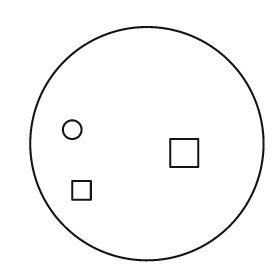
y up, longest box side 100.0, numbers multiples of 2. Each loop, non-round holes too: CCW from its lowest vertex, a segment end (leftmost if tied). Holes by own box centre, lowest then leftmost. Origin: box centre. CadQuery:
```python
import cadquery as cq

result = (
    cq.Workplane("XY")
    .moveTo(0.0, 0.0)
    .circle(50.0)
    .moveTo(-32.0, -24.0)
    .lineTo(-24.0, -24.0)
    .lineTo(-24.0, -16.0)
    .lineTo(-32.0, -16.0)
    .close()
    .moveTo(10.0, -10.0)
    .lineTo(22.0, -10.0)
    .lineTo(22.0, 2.0)
    .lineTo(10.0, 2.0)
    .close()
    .moveTo(-32.0, 6.0)
    .circle(4.0)
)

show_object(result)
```